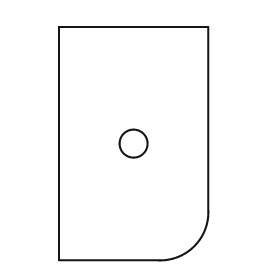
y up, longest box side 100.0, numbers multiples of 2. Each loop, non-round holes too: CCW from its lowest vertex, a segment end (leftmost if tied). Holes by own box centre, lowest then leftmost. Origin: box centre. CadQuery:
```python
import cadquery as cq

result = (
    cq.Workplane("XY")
    .moveTo(-32.0, -50.0)
    .lineTo(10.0, -50.0)
    .threePointArc((26.0, -44.0), (32.0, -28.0))
    .lineTo(32.0, 50.0)
    .lineTo(-32.0, 50.0)
    .close()
    .moveTo(0.0, 0.0)
    .circle(6.0)
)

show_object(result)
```